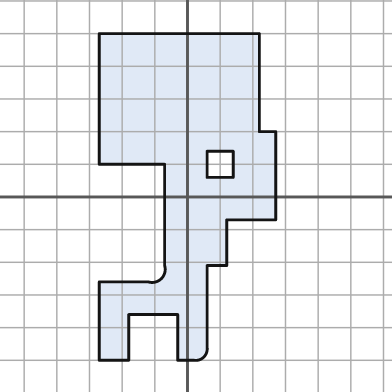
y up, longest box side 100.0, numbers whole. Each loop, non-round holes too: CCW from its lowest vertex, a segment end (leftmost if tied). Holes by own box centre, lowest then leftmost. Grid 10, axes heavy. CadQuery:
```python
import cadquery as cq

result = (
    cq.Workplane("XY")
    .moveTo(-27.0, -50.0)
    .lineTo(-18.0, -50.0)
    .lineTo(-18.0, -36.0)
    .lineTo(-3.0, -36.0)
    .lineTo(-3.0, -50.0)
    .lineTo(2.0, -50.0)
    .threePointArc((5.0, -49.0), (6.0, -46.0))
    .lineTo(6.0, -21.0)
    .lineTo(12.0, -21.0)
    .lineTo(12.0, -7.0)
    .lineTo(27.0, -7.0)
    .lineTo(27.0, 20.0)
    .lineTo(22.0, 20.0)
    .lineTo(22.0, 50.0)
    .lineTo(-27.0, 50.0)
    .lineTo(-27.0, 10.0)
    .lineTo(-7.0, 10.0)
    .lineTo(-7.0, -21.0)
    .threePointArc((-8.0, -25.0), (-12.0, -26.0))
    .lineTo(-27.0, -26.0)
    .close()
    .moveTo(6.0, 6.0)
    .lineTo(14.0, 6.0)
    .lineTo(14.0, 14.0)
    .lineTo(6.0, 14.0)
    .close()
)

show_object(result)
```